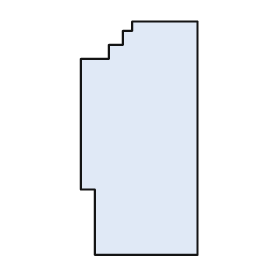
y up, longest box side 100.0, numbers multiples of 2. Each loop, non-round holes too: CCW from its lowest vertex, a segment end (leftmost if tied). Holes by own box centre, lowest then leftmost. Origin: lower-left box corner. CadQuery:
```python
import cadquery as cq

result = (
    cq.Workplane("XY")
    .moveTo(6.0, 0.0)
    .lineTo(50.0, 0.0)
    .lineTo(50.0, 100.0)
    .lineTo(22.0, 100.0)
    .lineTo(22.0, 96.0)
    .lineTo(18.0, 96.0)
    .lineTo(18.0, 90.0)
    .lineTo(12.0, 90.0)
    .lineTo(12.0, 84.0)
    .lineTo(0.0, 84.0)
    .lineTo(0.0, 28.0)
    .lineTo(6.0, 28.0)
    .close()
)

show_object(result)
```